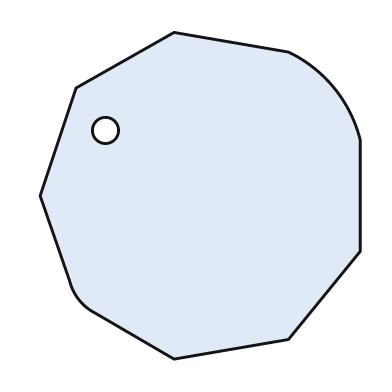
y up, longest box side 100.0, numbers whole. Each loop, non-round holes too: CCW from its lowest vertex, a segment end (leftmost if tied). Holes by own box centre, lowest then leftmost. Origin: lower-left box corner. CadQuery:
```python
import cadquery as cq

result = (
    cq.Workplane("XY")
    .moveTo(41.0, 0.0)
    .lineTo(76.0, 6.0)
    .lineTo(98.0, 33.0)
    .lineTo(98.0, 67.0)
    .threePointArc((90.0, 83.0), (76.0, 94.0))
    .lineTo(41.0, 100.0)
    .lineTo(11.0, 83.0)
    .lineTo(0.0, 50.0)
    .lineTo(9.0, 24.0)
    .threePointArc((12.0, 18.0), (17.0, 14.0))
    .close()
    .moveTo(20.0, 70.0)
    .circle(4.0)
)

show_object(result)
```